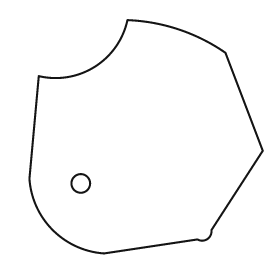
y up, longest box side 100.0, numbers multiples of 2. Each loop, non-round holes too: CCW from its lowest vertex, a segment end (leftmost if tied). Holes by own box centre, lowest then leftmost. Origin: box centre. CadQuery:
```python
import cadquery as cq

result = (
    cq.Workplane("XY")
    .moveTo(-18.0, -50.0)
    .lineTo(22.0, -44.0)
    .threePointArc((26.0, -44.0), (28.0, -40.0))
    .lineTo(50.0, -6.0)
    .lineTo(34.0, 36.0)
    .threePointArc((14.0, 46.0), (-8.0, 50.0))
    .threePointArc((-22.0, 30.0), (-46.0, 26.0))
    .lineTo(-50.0, -18.0)
    .threePointArc((-40.0, -40.0), (-18.0, -50.0))
    .close()
    .moveTo(-28.0, -20.0)
    .circle(4.0)
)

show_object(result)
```